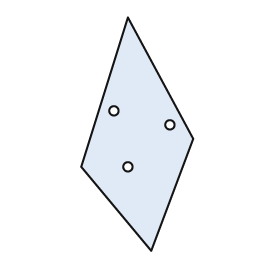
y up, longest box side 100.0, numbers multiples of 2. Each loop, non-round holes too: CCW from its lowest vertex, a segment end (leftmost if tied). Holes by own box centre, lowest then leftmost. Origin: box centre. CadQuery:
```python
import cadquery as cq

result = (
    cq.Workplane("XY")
    .moveTo(6.0, -50.0)
    .lineTo(24.0, -2.0)
    .lineTo(-4.0, 50.0)
    .lineTo(-24.0, -14.0)
    .close()
    .moveTo(-4.0, -14.0)
    .circle(2.0)
    .moveTo(14.0, 4.0)
    .circle(2.0)
    .moveTo(-10.0, 10.0)
    .circle(2.0)
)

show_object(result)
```